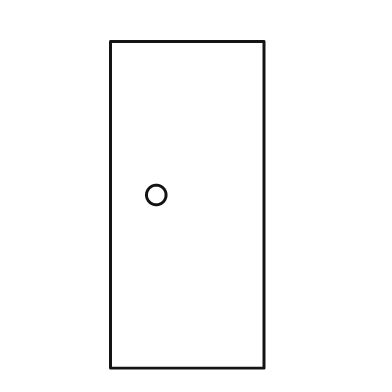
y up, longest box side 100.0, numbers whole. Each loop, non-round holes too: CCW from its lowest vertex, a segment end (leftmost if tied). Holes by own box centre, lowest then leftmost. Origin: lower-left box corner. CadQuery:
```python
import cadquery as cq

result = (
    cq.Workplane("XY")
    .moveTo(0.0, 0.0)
    .lineTo(47.0, 0.0)
    .lineTo(47.0, 100.0)
    .lineTo(0.0, 100.0)
    .close()
    .moveTo(14.0, 53.0)
    .circle(3.0)
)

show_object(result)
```